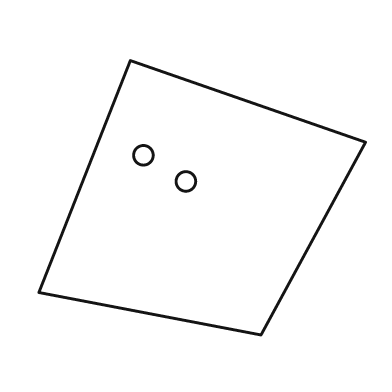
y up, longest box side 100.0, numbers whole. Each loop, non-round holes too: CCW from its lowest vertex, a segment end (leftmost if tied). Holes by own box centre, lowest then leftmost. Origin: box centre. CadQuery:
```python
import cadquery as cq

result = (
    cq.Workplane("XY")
    .moveTo(18.0, -42.0)
    .lineTo(50.0, 17.0)
    .lineTo(-22.0, 42.0)
    .lineTo(-50.0, -29.0)
    .close()
    .moveTo(-5.0, 5.0)
    .circle(3.0)
    .moveTo(-18.0, 13.0)
    .circle(3.0)
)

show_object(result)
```